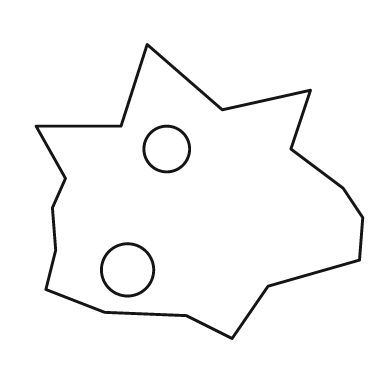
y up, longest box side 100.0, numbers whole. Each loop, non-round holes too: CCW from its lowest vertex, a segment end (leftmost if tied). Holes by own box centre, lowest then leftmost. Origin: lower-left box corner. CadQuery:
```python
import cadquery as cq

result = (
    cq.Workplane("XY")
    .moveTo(60.0, 0.0)
    .lineTo(71.0, 16.0)
    .lineTo(99.0, 24.0)
    .lineTo(100.0, 37.0)
    .lineTo(94.0, 46.0)
    .lineTo(78.0, 58.0)
    .lineTo(84.0, 76.0)
    .lineTo(57.0, 70.0)
    .lineTo(34.0, 90.0)
    .lineTo(26.0, 65.0)
    .lineTo(0.0, 65.0)
    .lineTo(9.0, 49.0)
    .lineTo(5.0, 40.0)
    .lineTo(6.0, 27.0)
    .lineTo(3.0, 15.0)
    .lineTo(21.0, 8.0)
    .lineTo(46.0, 7.0)
    .close()
    .moveTo(28.0, 21.0)
    .circle(8.0)
    .moveTo(40.0, 58.0)
    .circle(7.0)
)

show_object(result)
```